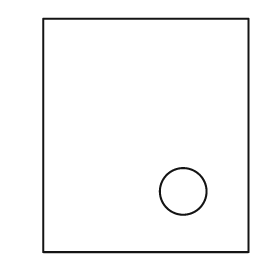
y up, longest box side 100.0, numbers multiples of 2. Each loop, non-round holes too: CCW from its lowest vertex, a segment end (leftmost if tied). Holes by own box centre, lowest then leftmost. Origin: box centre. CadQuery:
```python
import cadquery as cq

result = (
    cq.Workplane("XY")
    .moveTo(-44.0, -50.0)
    .lineTo(44.0, -50.0)
    .lineTo(44.0, 50.0)
    .lineTo(-44.0, 50.0)
    .close()
    .moveTo(16.0, -24.0)
    .circle(10.0)
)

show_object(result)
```